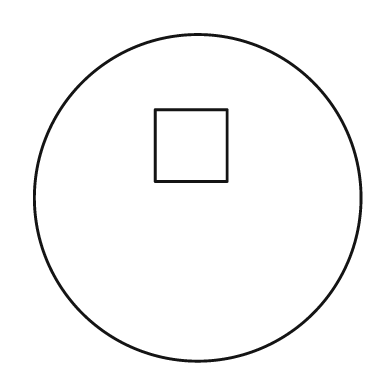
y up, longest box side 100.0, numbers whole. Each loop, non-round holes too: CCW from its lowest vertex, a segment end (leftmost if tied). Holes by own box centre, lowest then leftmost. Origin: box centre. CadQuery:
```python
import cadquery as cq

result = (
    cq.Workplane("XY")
    .moveTo(0.0, 0.0)
    .circle(50.0)
    .moveTo(-13.0, 5.0)
    .lineTo(9.0, 5.0)
    .lineTo(9.0, 27.0)
    .lineTo(-13.0, 27.0)
    .close()
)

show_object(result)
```